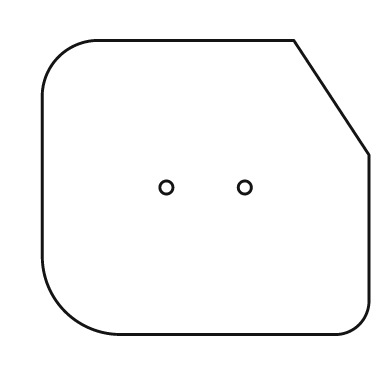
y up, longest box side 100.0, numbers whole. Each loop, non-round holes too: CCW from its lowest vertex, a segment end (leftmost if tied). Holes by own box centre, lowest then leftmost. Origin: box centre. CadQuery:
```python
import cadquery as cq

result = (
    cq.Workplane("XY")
    .moveTo(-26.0, -45.0)
    .lineTo(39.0, -45.0)
    .threePointArc((47.0, -42.0), (50.0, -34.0))
    .lineTo(50.0, 10.0)
    .lineTo(27.0, 45.0)
    .lineTo(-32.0, 45.0)
    .threePointArc((-45.0, 40.0), (-50.0, 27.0))
    .lineTo(-50.0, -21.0)
    .threePointArc((-43.0, -38.0), (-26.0, -45.0))
    .close()
    .moveTo(-12.0, 0.0)
    .circle(2.0)
    .moveTo(12.0, 0.0)
    .circle(2.0)
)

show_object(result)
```